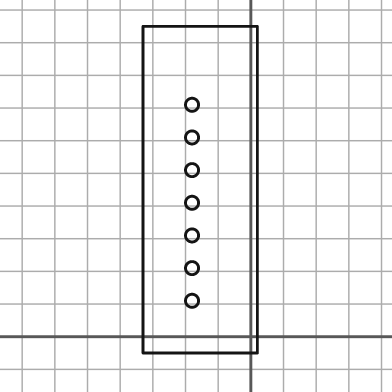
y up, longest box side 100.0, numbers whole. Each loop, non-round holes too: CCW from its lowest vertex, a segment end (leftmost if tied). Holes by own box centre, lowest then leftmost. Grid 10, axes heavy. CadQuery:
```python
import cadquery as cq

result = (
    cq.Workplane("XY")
    .moveTo(-33.0, -5.0)
    .lineTo(2.0, -5.0)
    .lineTo(2.0, 95.0)
    .lineTo(-33.0, 95.0)
    .close()
    .moveTo(-18.0, 11.0)
    .circle(2.0)
    .moveTo(-18.0, 21.0)
    .circle(2.0)
    .moveTo(-18.0, 31.0)
    .circle(2.0)
    .moveTo(-18.0, 41.0)
    .circle(2.0)
    .moveTo(-18.0, 51.0)
    .circle(2.0)
    .moveTo(-18.0, 61.0)
    .circle(2.0)
    .moveTo(-18.0, 71.0)
    .circle(2.0)
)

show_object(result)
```